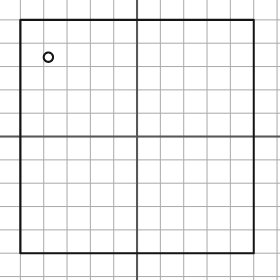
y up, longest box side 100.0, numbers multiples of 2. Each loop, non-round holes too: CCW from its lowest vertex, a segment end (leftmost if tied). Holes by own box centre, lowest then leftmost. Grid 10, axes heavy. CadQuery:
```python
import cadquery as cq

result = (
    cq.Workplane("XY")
    .moveTo(-50.0, -50.0)
    .lineTo(50.0, -50.0)
    .lineTo(50.0, 50.0)
    .lineTo(-50.0, 50.0)
    .close()
    .moveTo(-38.0, 34.0)
    .circle(2.0)
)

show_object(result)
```